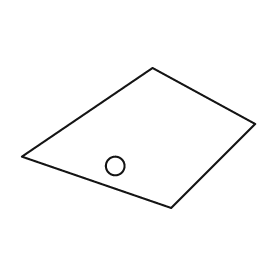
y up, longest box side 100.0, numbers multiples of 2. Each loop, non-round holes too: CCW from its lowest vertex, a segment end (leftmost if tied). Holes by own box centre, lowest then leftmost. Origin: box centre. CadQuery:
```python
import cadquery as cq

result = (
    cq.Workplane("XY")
    .moveTo(14.0, -30.0)
    .lineTo(50.0, 6.0)
    .lineTo(6.0, 30.0)
    .lineTo(-50.0, -8.0)
    .close()
    .moveTo(-10.0, -12.0)
    .circle(4.0)
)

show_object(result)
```